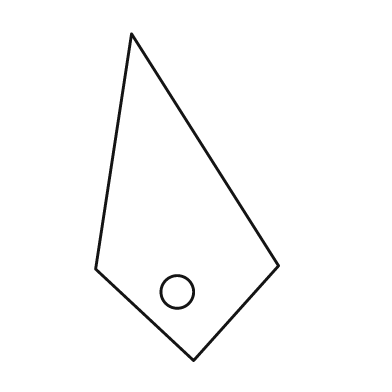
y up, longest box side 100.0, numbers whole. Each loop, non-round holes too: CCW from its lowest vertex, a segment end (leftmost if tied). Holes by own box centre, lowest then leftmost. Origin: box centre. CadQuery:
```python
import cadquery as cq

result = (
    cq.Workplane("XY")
    .moveTo(2.0, -50.0)
    .lineTo(28.0, -21.0)
    .lineTo(-17.0, 50.0)
    .lineTo(-28.0, -22.0)
    .close()
    .moveTo(-3.0, -29.0)
    .circle(5.0)
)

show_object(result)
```